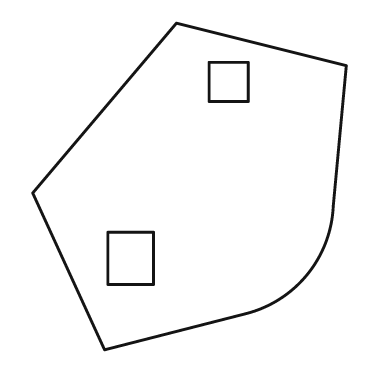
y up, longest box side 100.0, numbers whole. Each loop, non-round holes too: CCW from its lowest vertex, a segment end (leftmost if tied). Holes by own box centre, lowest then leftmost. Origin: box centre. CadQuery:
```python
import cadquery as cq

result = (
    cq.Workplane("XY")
    .moveTo(-26.0, -50.0)
    .lineTo(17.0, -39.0)
    .threePointArc((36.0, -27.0), (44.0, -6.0))
    .lineTo(48.0, 37.0)
    .lineTo(-4.0, 50.0)
    .lineTo(-48.0, -2.0)
    .close()
    .moveTo(-25.0, -30.0)
    .lineTo(-11.0, -30.0)
    .lineTo(-11.0, -14.0)
    .lineTo(-25.0, -14.0)
    .close()
    .moveTo(6.0, 26.0)
    .lineTo(18.0, 26.0)
    .lineTo(18.0, 38.0)
    .lineTo(6.0, 38.0)
    .close()
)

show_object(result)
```